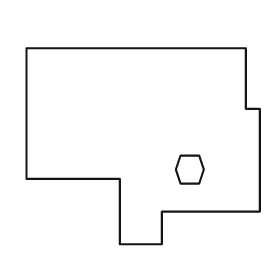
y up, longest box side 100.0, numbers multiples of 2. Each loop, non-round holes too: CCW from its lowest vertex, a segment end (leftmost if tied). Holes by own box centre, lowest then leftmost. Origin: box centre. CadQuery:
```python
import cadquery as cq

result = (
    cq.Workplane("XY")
    .moveTo(-10.0, -42.0)
    .lineTo(8.0, -42.0)
    .lineTo(8.0, -28.0)
    .lineTo(50.0, -28.0)
    .lineTo(50.0, 16.0)
    .lineTo(44.0, 16.0)
    .lineTo(44.0, 42.0)
    .lineTo(-50.0, 42.0)
    .lineTo(-50.0, -14.0)
    .lineTo(-10.0, -14.0)
    .close()
    .moveTo(16.0, -16.0)
    .lineTo(24.0, -16.0)
    .lineTo(26.0, -10.0)
    .lineTo(24.0, -4.0)
    .lineTo(16.0, -4.0)
    .lineTo(14.0, -10.0)
    .close()
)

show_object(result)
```